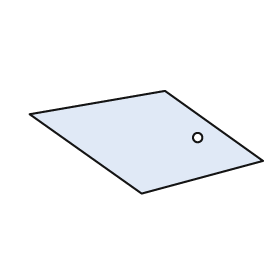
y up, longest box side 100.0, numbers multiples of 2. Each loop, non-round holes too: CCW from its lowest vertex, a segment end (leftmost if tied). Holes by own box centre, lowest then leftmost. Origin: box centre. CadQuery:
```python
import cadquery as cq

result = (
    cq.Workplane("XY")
    .moveTo(-2.0, -22.0)
    .lineTo(50.0, -8.0)
    .lineTo(8.0, 22.0)
    .lineTo(-50.0, 12.0)
    .close()
    .moveTo(22.0, 2.0)
    .circle(2.0)
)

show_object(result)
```